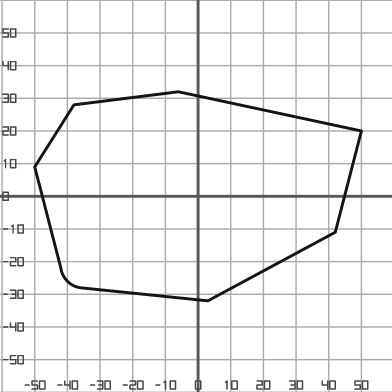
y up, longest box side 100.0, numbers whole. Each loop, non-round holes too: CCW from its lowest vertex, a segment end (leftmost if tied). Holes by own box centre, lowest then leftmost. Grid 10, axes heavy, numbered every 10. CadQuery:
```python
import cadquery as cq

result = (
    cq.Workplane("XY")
    .moveTo(3.0, -32.0)
    .lineTo(42.0, -11.0)
    .lineTo(50.0, 20.0)
    .lineTo(-6.0, 32.0)
    .lineTo(-38.0, 28.0)
    .lineTo(-50.0, 9.0)
    .lineTo(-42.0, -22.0)
    .threePointArc((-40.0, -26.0), (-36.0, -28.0))
    .close()
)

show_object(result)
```